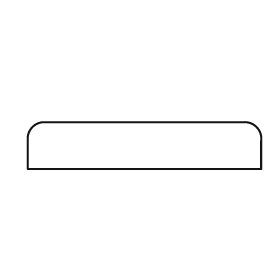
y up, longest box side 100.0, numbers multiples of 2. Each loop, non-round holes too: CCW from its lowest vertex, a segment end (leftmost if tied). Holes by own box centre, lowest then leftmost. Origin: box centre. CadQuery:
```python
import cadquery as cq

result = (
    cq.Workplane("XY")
    .moveTo(-50.0, -10.0)
    .lineTo(50.0, -10.0)
    .lineTo(50.0, 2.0)
    .threePointArc((48.0, 8.0), (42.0, 10.0))
    .lineTo(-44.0, 10.0)
    .threePointArc((-48.0, 8.0), (-50.0, 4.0))
    .close()
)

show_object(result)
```